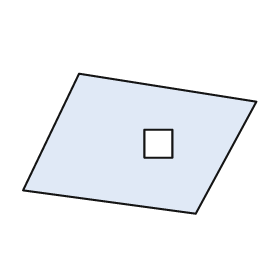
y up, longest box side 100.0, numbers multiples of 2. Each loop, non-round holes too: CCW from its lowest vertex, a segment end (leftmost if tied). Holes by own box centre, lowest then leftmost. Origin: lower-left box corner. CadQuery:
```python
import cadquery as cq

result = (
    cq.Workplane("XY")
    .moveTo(74.0, 0.0)
    .lineTo(100.0, 48.0)
    .lineTo(24.0, 60.0)
    .lineTo(0.0, 10.0)
    .close()
    .moveTo(52.0, 24.0)
    .lineTo(64.0, 24.0)
    .lineTo(64.0, 36.0)
    .lineTo(52.0, 36.0)
    .close()
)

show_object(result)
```